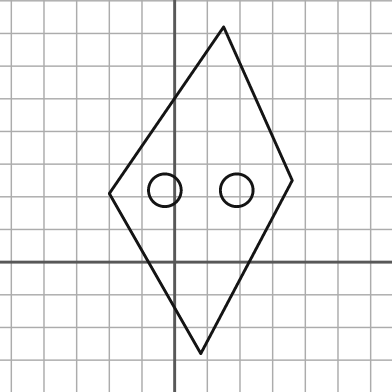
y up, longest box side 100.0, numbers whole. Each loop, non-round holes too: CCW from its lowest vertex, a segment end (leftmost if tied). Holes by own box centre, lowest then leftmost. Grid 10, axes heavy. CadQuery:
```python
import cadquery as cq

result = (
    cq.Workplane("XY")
    .moveTo(8.0, -28.0)
    .lineTo(36.0, 25.0)
    .lineTo(15.0, 72.0)
    .lineTo(-20.0, 21.0)
    .close()
    .moveTo(-3.0, 22.0)
    .circle(5.0)
    .moveTo(19.0, 22.0)
    .circle(5.0)
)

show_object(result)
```